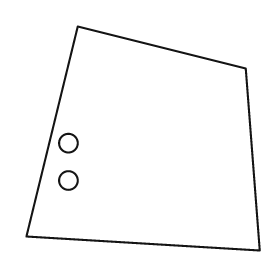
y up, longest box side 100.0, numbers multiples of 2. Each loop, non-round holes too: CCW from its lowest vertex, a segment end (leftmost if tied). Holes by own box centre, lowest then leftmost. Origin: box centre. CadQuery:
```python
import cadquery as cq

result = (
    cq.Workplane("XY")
    .moveTo(50.0, -48.0)
    .lineTo(44.0, 30.0)
    .lineTo(-28.0, 48.0)
    .lineTo(-50.0, -42.0)
    .close()
    .moveTo(-32.0, -18.0)
    .circle(4.0)
    .moveTo(-32.0, -2.0)
    .circle(4.0)
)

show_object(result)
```